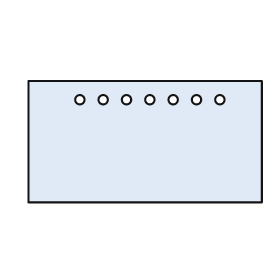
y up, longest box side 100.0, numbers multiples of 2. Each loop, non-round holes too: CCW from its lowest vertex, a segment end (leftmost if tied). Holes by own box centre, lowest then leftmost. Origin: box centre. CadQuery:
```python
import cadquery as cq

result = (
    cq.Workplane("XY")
    .moveTo(-50.0, -26.0)
    .lineTo(50.0, -26.0)
    .lineTo(50.0, 26.0)
    .lineTo(-50.0, 26.0)
    .close()
    .moveTo(-28.0, 18.0)
    .circle(2.0)
    .moveTo(-18.0, 18.0)
    .circle(2.0)
    .moveTo(-8.0, 18.0)
    .circle(2.0)
    .moveTo(2.0, 18.0)
    .circle(2.0)
    .moveTo(12.0, 18.0)
    .circle(2.0)
    .moveTo(22.0, 18.0)
    .circle(2.0)
    .moveTo(32.0, 18.0)
    .circle(2.0)
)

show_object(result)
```